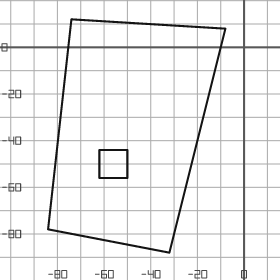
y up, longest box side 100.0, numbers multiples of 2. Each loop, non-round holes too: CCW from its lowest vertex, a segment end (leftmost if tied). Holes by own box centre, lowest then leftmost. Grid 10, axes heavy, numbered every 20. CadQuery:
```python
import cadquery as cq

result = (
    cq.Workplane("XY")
    .moveTo(-32.0, -88.0)
    .lineTo(-8.0, 8.0)
    .lineTo(-74.0, 12.0)
    .lineTo(-84.0, -78.0)
    .close()
    .moveTo(-62.0, -56.0)
    .lineTo(-50.0, -56.0)
    .lineTo(-50.0, -44.0)
    .lineTo(-62.0, -44.0)
    .close()
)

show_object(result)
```